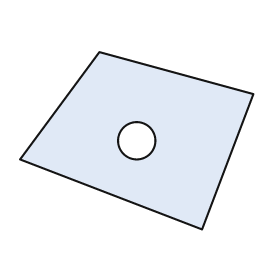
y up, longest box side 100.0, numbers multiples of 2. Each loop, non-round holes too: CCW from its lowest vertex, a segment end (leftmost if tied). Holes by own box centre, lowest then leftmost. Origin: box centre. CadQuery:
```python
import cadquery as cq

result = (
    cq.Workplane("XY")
    .moveTo(28.0, -38.0)
    .lineTo(50.0, 20.0)
    .lineTo(-16.0, 38.0)
    .lineTo(-50.0, -8.0)
    .close()
    .moveTo(0.0, 0.0)
    .circle(8.0)
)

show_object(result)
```